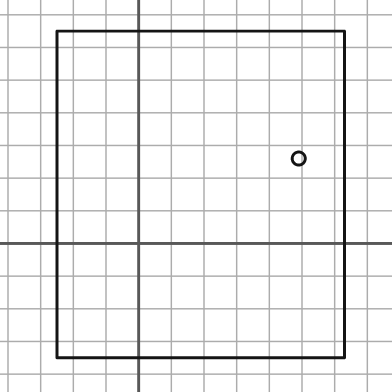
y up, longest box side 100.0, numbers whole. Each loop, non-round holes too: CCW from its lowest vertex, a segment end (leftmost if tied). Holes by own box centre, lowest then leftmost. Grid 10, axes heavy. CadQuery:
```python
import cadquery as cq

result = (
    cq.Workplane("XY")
    .moveTo(-25.0, -35.0)
    .lineTo(63.0, -35.0)
    .lineTo(63.0, 65.0)
    .lineTo(-25.0, 65.0)
    .close()
    .moveTo(49.0, 26.0)
    .circle(2.0)
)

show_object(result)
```